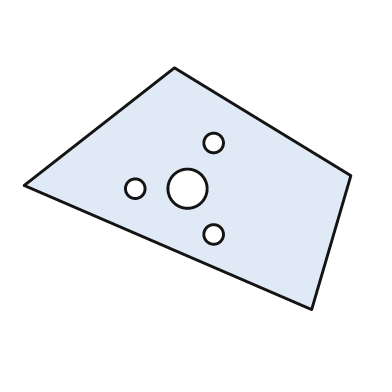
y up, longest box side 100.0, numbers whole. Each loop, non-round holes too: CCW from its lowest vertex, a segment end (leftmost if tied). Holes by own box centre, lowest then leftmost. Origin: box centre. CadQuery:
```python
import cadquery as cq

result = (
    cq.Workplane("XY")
    .moveTo(38.0, -37.0)
    .lineTo(50.0, 4.0)
    .lineTo(-4.0, 37.0)
    .lineTo(-50.0, 1.0)
    .close()
    .moveTo(8.0, -14.0)
    .circle(3.0)
    .moveTo(-16.0, 0.0)
    .circle(3.0)
    .moveTo(0.0, 0.0)
    .circle(6.0)
    .moveTo(8.0, 14.0)
    .circle(3.0)
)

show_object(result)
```